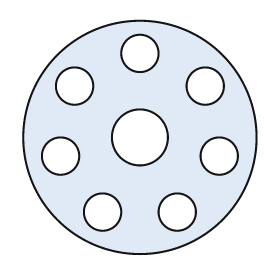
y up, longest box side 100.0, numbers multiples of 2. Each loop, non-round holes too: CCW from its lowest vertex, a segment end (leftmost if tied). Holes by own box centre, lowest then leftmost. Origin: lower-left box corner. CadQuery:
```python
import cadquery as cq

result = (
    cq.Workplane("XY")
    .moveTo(50.0, 50.0)
    .circle(50.0)
    .moveTo(34.0, 18.0)
    .circle(8.0)
    .moveTo(66.0, 18.0)
    .circle(8.0)
    .moveTo(16.0, 42.0)
    .circle(8.0)
    .moveTo(84.0, 42.0)
    .circle(8.0)
    .moveTo(50.0, 50.0)
    .circle(12.0)
    .moveTo(22.0, 72.0)
    .circle(8.0)
    .moveTo(78.0, 72.0)
    .circle(8.0)
    .moveTo(50.0, 86.0)
    .circle(8.0)
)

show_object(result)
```